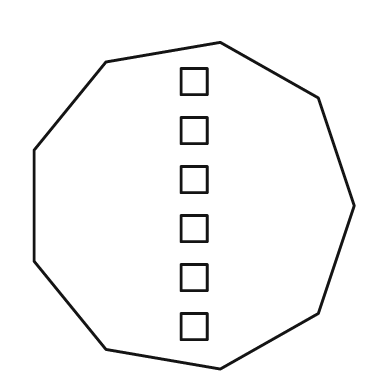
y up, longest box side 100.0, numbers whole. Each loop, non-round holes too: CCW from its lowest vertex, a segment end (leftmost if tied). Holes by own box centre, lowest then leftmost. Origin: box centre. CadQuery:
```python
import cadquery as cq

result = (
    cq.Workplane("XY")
    .moveTo(8.0, -50.0)
    .lineTo(38.0, -33.0)
    .lineTo(49.0, 0.0)
    .lineTo(38.0, 33.0)
    .lineTo(8.0, 50.0)
    .lineTo(-27.0, 44.0)
    .lineTo(-49.0, 17.0)
    .lineTo(-49.0, -17.0)
    .lineTo(-27.0, -44.0)
    .close()
    .moveTo(-4.0, -41.0)
    .lineTo(4.0, -41.0)
    .lineTo(4.0, -33.0)
    .lineTo(-4.0, -33.0)
    .close()
    .moveTo(-4.0, -26.0)
    .lineTo(4.0, -26.0)
    .lineTo(4.0, -18.0)
    .lineTo(-4.0, -18.0)
    .close()
    .moveTo(-4.0, -11.0)
    .lineTo(4.0, -11.0)
    .lineTo(4.0, -3.0)
    .lineTo(-4.0, -3.0)
    .close()
    .moveTo(-4.0, 4.0)
    .lineTo(4.0, 4.0)
    .lineTo(4.0, 12.0)
    .lineTo(-4.0, 12.0)
    .close()
    .moveTo(-4.0, 19.0)
    .lineTo(4.0, 19.0)
    .lineTo(4.0, 27.0)
    .lineTo(-4.0, 27.0)
    .close()
    .moveTo(-4.0, 34.0)
    .lineTo(4.0, 34.0)
    .lineTo(4.0, 42.0)
    .lineTo(-4.0, 42.0)
    .close()
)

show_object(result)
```